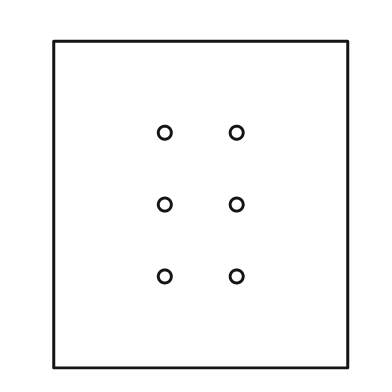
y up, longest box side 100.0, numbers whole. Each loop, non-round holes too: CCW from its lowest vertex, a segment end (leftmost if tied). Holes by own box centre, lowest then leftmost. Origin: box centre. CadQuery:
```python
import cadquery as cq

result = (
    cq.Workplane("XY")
    .moveTo(-45.0, -50.0)
    .lineTo(45.0, -50.0)
    .lineTo(45.0, 50.0)
    .lineTo(-45.0, 50.0)
    .close()
    .moveTo(-11.0, -22.0)
    .circle(2.0)
    .moveTo(11.0, -22.0)
    .circle(2.0)
    .moveTo(-11.0, 0.0)
    .circle(2.0)
    .moveTo(11.0, 0.0)
    .circle(2.0)
    .moveTo(-11.0, 22.0)
    .circle(2.0)
    .moveTo(11.0, 22.0)
    .circle(2.0)
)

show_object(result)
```